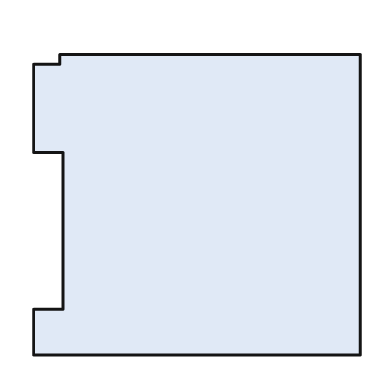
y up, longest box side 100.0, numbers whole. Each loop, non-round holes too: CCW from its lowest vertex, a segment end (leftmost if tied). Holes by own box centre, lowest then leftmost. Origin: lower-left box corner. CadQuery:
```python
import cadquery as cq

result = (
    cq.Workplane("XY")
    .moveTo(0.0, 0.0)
    .lineTo(100.0, 0.0)
    .lineTo(100.0, 92.0)
    .lineTo(8.0, 92.0)
    .lineTo(8.0, 89.0)
    .lineTo(0.0, 89.0)
    .lineTo(0.0, 62.0)
    .lineTo(9.0, 62.0)
    .lineTo(9.0, 14.0)
    .lineTo(0.0, 14.0)
    .close()
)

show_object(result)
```